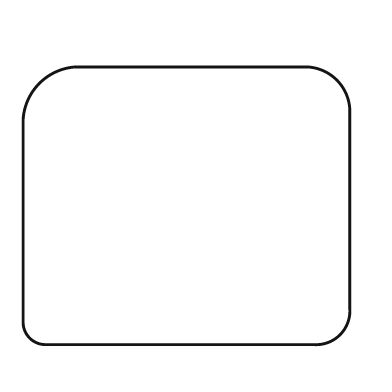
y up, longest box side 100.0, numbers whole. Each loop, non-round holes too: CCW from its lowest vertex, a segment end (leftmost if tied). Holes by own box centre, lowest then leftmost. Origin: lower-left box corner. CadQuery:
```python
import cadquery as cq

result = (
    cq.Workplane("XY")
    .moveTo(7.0, 0.0)
    .lineTo(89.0, 0.0)
    .threePointArc((97.0, 3.0), (100.0, 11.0))
    .lineTo(100.0, 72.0)
    .threePointArc((96.0, 81.0), (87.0, 85.0))
    .lineTo(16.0, 85.0)
    .threePointArc((5.0, 80.0), (0.0, 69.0))
    .lineTo(0.0, 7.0)
    .threePointArc((2.0, 2.0), (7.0, 0.0))
    .close()
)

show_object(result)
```